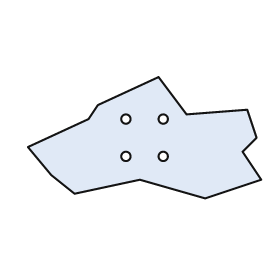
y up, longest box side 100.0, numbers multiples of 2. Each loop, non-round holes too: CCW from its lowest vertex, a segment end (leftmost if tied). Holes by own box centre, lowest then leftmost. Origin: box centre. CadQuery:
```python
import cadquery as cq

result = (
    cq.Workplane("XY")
    .moveTo(26.0, -26.0)
    .lineTo(50.0, -18.0)
    .lineTo(42.0, -6.0)
    .lineTo(48.0, 0.0)
    .lineTo(44.0, 12.0)
    .lineTo(18.0, 10.0)
    .lineTo(6.0, 26.0)
    .lineTo(-20.0, 14.0)
    .lineTo(-24.0, 8.0)
    .lineTo(-50.0, -4.0)
    .lineTo(-40.0, -16.0)
    .lineTo(-30.0, -24.0)
    .lineTo(-2.0, -18.0)
    .close()
    .moveTo(-8.0, -8.0)
    .circle(2.0)
    .moveTo(8.0, -8.0)
    .circle(2.0)
    .moveTo(-8.0, 8.0)
    .circle(2.0)
    .moveTo(8.0, 8.0)
    .circle(2.0)
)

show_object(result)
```